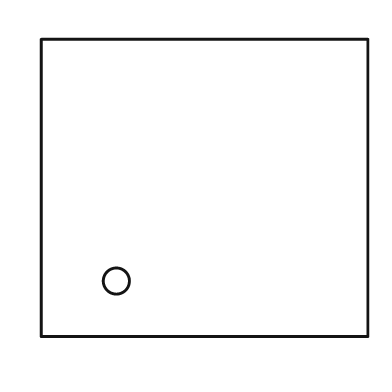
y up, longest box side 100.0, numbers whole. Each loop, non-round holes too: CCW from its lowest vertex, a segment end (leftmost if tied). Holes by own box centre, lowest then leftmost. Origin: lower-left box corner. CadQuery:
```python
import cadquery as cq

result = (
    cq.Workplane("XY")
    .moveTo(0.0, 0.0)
    .lineTo(100.0, 0.0)
    .lineTo(100.0, 91.0)
    .lineTo(0.0, 91.0)
    .close()
    .moveTo(23.0, 17.0)
    .circle(4.0)
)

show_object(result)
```